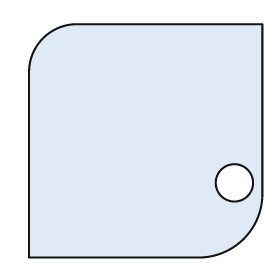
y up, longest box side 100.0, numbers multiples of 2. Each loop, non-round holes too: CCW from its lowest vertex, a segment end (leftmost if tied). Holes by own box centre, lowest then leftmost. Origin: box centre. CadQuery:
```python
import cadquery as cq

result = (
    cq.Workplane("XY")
    .moveTo(-50.0, -50.0)
    .lineTo(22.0, -50.0)
    .threePointArc((42.0, -42.0), (50.0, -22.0))
    .lineTo(50.0, 50.0)
    .lineTo(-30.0, 50.0)
    .threePointArc((-44.0, 44.0), (-50.0, 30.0))
    .close()
    .moveTo(38.0, -18.0)
    .circle(8.0)
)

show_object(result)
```